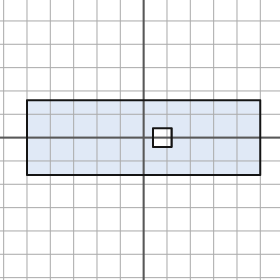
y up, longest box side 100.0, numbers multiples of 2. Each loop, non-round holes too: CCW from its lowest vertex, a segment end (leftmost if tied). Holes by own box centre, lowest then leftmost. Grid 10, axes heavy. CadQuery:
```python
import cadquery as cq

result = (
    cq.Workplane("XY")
    .moveTo(-50.0, -16.0)
    .lineTo(50.0, -16.0)
    .lineTo(50.0, 16.0)
    .lineTo(-50.0, 16.0)
    .close()
    .moveTo(4.0, -4.0)
    .lineTo(12.0, -4.0)
    .lineTo(12.0, 4.0)
    .lineTo(4.0, 4.0)
    .close()
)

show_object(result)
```